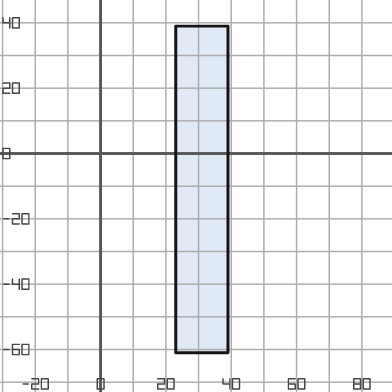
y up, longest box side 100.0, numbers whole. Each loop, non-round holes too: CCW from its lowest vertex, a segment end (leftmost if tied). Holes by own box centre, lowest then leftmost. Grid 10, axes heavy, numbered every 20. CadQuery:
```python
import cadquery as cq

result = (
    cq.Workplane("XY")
    .moveTo(23.0, -61.0)
    .lineTo(39.0, -61.0)
    .lineTo(39.0, 39.0)
    .lineTo(23.0, 39.0)
    .close()
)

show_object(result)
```